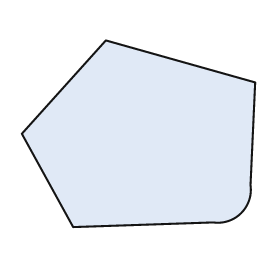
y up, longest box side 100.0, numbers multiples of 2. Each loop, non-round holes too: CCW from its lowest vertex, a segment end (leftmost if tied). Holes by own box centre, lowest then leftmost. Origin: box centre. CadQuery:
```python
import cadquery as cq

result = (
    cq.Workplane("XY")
    .moveTo(-28.0, -40.0)
    .lineTo(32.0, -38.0)
    .threePointArc((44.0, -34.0), (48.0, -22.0))
    .lineTo(50.0, 22.0)
    .lineTo(-14.0, 40.0)
    .lineTo(-50.0, 0.0)
    .close()
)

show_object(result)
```